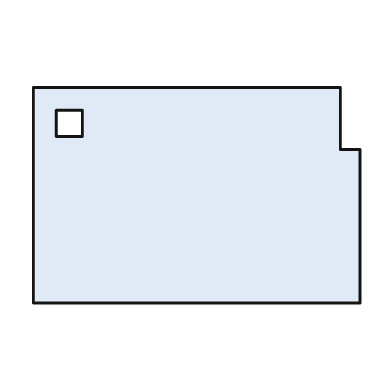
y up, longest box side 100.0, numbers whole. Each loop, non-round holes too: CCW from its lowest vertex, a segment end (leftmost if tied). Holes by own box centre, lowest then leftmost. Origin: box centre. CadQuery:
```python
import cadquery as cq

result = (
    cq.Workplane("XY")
    .moveTo(-50.0, -33.0)
    .lineTo(50.0, -33.0)
    .lineTo(50.0, 14.0)
    .lineTo(44.0, 14.0)
    .lineTo(44.0, 33.0)
    .lineTo(-50.0, 33.0)
    .close()
    .moveTo(-43.0, 18.0)
    .lineTo(-35.0, 18.0)
    .lineTo(-35.0, 26.0)
    .lineTo(-43.0, 26.0)
    .close()
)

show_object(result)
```